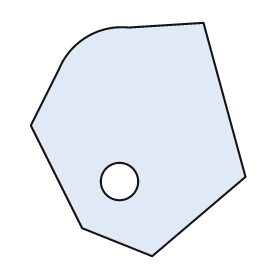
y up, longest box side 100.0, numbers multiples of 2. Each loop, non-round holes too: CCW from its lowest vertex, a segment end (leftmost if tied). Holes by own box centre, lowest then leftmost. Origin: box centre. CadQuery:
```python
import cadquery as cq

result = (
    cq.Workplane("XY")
    .moveTo(6.0, -50.0)
    .lineTo(46.0, -16.0)
    .lineTo(28.0, 50.0)
    .lineTo(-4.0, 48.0)
    .threePointArc((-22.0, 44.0), (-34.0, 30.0))
    .lineTo(-46.0, 6.0)
    .lineTo(-24.0, -38.0)
    .close()
    .moveTo(-8.0, -18.0)
    .circle(8.0)
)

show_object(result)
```